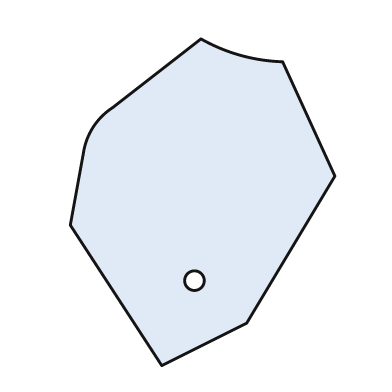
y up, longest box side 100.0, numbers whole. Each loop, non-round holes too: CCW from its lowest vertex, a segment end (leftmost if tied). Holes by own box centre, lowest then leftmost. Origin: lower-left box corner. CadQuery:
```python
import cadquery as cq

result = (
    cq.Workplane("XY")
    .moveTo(28.0, 0.0)
    .lineTo(54.0, 13.0)
    .lineTo(81.0, 58.0)
    .lineTo(65.0, 93.0)
    .threePointArc((52.0, 95.0), (40.0, 100.0))
    .lineTo(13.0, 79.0)
    .threePointArc((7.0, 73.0), (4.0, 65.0))
    .lineTo(0.0, 43.0)
    .close()
    .moveTo(38.0, 26.0)
    .circle(3.0)
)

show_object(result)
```